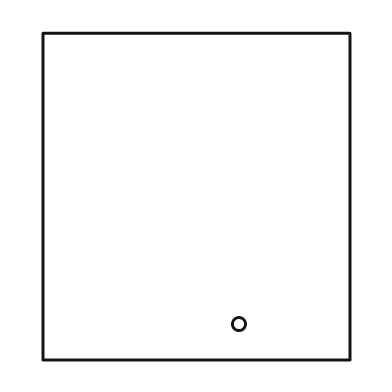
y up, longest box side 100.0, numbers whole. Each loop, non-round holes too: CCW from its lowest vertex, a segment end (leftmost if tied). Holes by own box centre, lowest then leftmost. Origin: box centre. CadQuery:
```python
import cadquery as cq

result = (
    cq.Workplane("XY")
    .moveTo(-47.0, -50.0)
    .lineTo(47.0, -50.0)
    .lineTo(47.0, 50.0)
    .lineTo(-47.0, 50.0)
    .close()
    .moveTo(13.0, -39.0)
    .circle(2.0)
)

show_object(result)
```